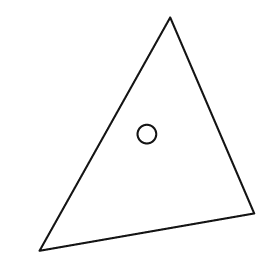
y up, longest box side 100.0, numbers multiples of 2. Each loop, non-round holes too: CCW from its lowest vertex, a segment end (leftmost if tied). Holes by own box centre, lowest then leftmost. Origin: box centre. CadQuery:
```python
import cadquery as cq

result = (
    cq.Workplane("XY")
    .moveTo(-46.0, -50.0)
    .lineTo(46.0, -34.0)
    .lineTo(10.0, 50.0)
    .close()
    .moveTo(0.0, 0.0)
    .circle(4.0)
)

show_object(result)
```